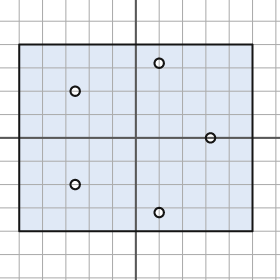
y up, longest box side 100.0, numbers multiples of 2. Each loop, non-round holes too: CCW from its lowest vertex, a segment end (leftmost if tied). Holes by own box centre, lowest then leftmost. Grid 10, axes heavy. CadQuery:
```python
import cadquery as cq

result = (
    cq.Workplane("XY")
    .moveTo(-50.0, -40.0)
    .lineTo(50.0, -40.0)
    .lineTo(50.0, 40.0)
    .lineTo(-50.0, 40.0)
    .close()
    .moveTo(10.0, -32.0)
    .circle(2.0)
    .moveTo(-26.0, -20.0)
    .circle(2.0)
    .moveTo(32.0, 0.0)
    .circle(2.0)
    .moveTo(-26.0, 20.0)
    .circle(2.0)
    .moveTo(10.0, 32.0)
    .circle(2.0)
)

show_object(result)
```